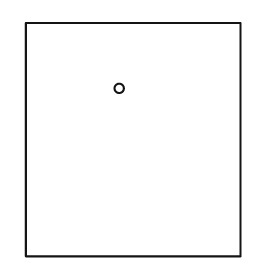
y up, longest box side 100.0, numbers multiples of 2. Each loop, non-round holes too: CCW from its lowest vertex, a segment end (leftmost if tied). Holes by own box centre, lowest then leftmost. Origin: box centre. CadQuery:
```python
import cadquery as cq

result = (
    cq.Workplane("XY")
    .moveTo(-46.0, -50.0)
    .lineTo(46.0, -50.0)
    .lineTo(46.0, 50.0)
    .lineTo(-46.0, 50.0)
    .close()
    .moveTo(-6.0, 22.0)
    .circle(2.0)
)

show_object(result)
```